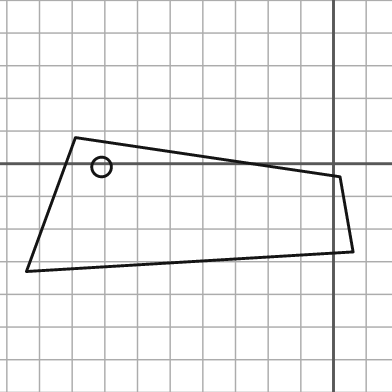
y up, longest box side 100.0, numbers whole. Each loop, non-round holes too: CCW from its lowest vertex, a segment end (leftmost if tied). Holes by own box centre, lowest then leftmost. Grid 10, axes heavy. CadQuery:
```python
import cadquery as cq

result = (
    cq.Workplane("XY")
    .moveTo(-94.0, -33.0)
    .lineTo(6.0, -27.0)
    .lineTo(2.0, -4.0)
    .lineTo(-79.0, 8.0)
    .close()
    .moveTo(-71.0, -1.0)
    .circle(3.0)
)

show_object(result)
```